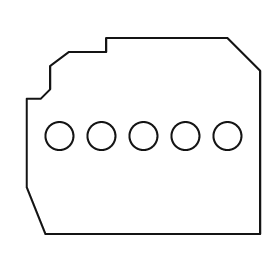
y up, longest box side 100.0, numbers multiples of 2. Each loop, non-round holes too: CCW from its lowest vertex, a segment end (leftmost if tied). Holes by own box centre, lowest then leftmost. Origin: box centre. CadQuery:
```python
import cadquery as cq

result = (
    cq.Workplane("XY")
    .moveTo(-42.0, -42.0)
    .lineTo(50.0, -42.0)
    .lineTo(50.0, 28.0)
    .lineTo(36.0, 42.0)
    .lineTo(-16.0, 42.0)
    .lineTo(-16.0, 36.0)
    .lineTo(-32.0, 36.0)
    .lineTo(-40.0, 30.0)
    .lineTo(-40.0, 20.0)
    .lineTo(-44.0, 16.0)
    .lineTo(-50.0, 16.0)
    .lineTo(-50.0, -22.0)
    .close()
    .moveTo(-36.0, 0.0)
    .circle(6.0)
    .moveTo(-18.0, 0.0)
    .circle(6.0)
    .moveTo(0.0, 0.0)
    .circle(6.0)
    .moveTo(18.0, 0.0)
    .circle(6.0)
    .moveTo(36.0, 0.0)
    .circle(6.0)
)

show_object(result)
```